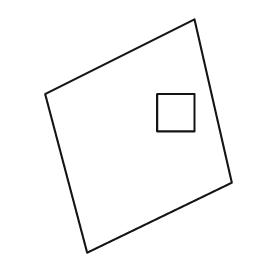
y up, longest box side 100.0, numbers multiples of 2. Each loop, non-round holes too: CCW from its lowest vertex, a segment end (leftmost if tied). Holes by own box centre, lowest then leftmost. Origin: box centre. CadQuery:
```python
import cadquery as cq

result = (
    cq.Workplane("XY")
    .moveTo(-22.0, -50.0)
    .lineTo(40.0, -20.0)
    .lineTo(24.0, 50.0)
    .lineTo(-40.0, 18.0)
    .close()
    .moveTo(8.0, 2.0)
    .lineTo(24.0, 2.0)
    .lineTo(24.0, 18.0)
    .lineTo(8.0, 18.0)
    .close()
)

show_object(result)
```